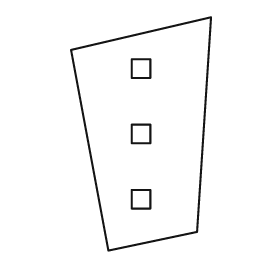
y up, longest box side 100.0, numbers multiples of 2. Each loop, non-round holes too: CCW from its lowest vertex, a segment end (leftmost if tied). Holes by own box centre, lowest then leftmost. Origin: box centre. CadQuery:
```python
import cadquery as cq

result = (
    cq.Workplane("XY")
    .moveTo(-14.0, -50.0)
    .lineTo(24.0, -42.0)
    .lineTo(30.0, 50.0)
    .lineTo(-30.0, 36.0)
    .close()
    .moveTo(-4.0, -32.0)
    .lineTo(4.0, -32.0)
    .lineTo(4.0, -24.0)
    .lineTo(-4.0, -24.0)
    .close()
    .moveTo(-4.0, -4.0)
    .lineTo(4.0, -4.0)
    .lineTo(4.0, 4.0)
    .lineTo(-4.0, 4.0)
    .close()
    .moveTo(-4.0, 24.0)
    .lineTo(4.0, 24.0)
    .lineTo(4.0, 32.0)
    .lineTo(-4.0, 32.0)
    .close()
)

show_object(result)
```